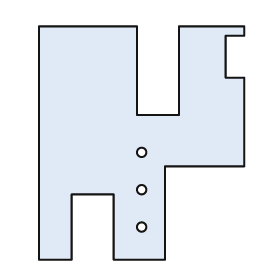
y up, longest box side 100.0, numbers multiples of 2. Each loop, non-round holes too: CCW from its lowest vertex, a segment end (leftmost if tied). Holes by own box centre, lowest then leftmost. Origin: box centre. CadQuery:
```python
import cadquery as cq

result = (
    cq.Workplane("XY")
    .moveTo(-44.0, -50.0)
    .lineTo(-30.0, -50.0)
    .lineTo(-30.0, -22.0)
    .lineTo(-12.0, -22.0)
    .lineTo(-12.0, -50.0)
    .lineTo(10.0, -50.0)
    .lineTo(10.0, -10.0)
    .lineTo(44.0, -10.0)
    .lineTo(44.0, 28.0)
    .lineTo(36.0, 28.0)
    .lineTo(36.0, 46.0)
    .lineTo(44.0, 46.0)
    .lineTo(44.0, 50.0)
    .lineTo(16.0, 50.0)
    .lineTo(16.0, 12.0)
    .lineTo(-2.0, 12.0)
    .lineTo(-2.0, 50.0)
    .lineTo(-44.0, 50.0)
    .close()
    .moveTo(0.0, -36.0)
    .circle(2.0)
    .moveTo(0.0, -20.0)
    .circle(2.0)
    .moveTo(0.0, -4.0)
    .circle(2.0)
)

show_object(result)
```